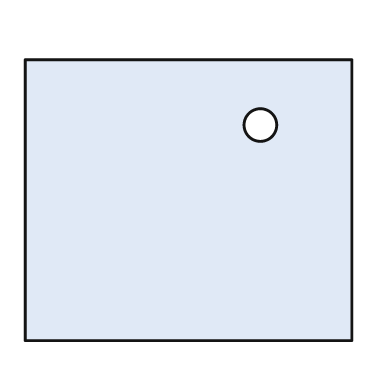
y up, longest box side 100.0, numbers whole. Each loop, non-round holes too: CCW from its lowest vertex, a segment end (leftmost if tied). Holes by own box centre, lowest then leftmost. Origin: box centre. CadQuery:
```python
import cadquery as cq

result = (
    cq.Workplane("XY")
    .moveTo(-50.0, -43.0)
    .lineTo(50.0, -43.0)
    .lineTo(50.0, 43.0)
    .lineTo(-50.0, 43.0)
    .close()
    .moveTo(22.0, 23.0)
    .circle(5.0)
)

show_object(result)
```